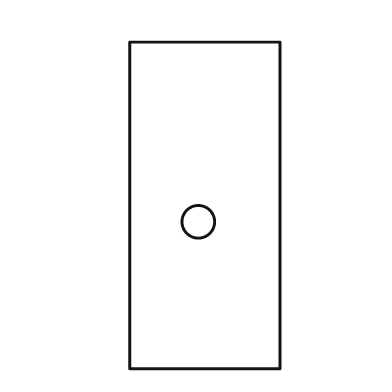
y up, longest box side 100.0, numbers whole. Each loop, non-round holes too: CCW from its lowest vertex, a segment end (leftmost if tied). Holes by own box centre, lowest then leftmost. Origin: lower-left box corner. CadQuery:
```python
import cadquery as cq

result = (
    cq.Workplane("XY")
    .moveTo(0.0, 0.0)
    .lineTo(46.0, 0.0)
    .lineTo(46.0, 100.0)
    .lineTo(0.0, 100.0)
    .close()
    .moveTo(21.0, 45.0)
    .circle(5.0)
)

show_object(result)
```